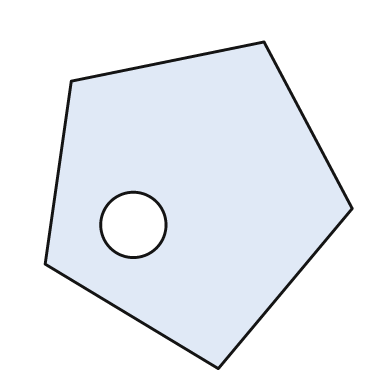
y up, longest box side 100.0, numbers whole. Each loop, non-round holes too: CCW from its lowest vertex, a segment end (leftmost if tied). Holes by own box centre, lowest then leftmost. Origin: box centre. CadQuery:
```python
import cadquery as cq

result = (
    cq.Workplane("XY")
    .moveTo(6.0, -50.0)
    .lineTo(47.0, -1.0)
    .lineTo(20.0, 50.0)
    .lineTo(-39.0, 38.0)
    .lineTo(-47.0, -18.0)
    .close()
    .moveTo(-20.0, -6.0)
    .circle(10.0)
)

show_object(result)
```